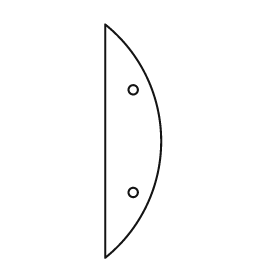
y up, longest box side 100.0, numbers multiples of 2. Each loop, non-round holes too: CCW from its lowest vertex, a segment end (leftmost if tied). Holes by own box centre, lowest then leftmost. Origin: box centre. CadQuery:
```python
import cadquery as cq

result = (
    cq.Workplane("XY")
    .moveTo(-12.0, -50.0)
    .threePointArc((12.0, 0.0), (-12.0, 50.0))
    .close()
    .moveTo(0.0, -22.0)
    .circle(2.0)
    .moveTo(0.0, 22.0)
    .circle(2.0)
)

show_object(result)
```